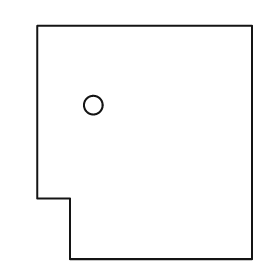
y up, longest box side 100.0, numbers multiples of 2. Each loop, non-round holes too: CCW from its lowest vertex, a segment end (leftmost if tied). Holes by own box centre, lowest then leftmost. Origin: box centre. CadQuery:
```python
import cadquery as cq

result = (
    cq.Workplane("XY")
    .moveTo(-32.0, -50.0)
    .lineTo(46.0, -50.0)
    .lineTo(46.0, 50.0)
    .lineTo(-46.0, 50.0)
    .lineTo(-46.0, -24.0)
    .lineTo(-32.0, -24.0)
    .close()
    .moveTo(-22.0, 16.0)
    .circle(4.0)
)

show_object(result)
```